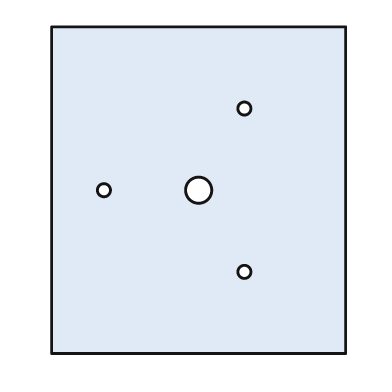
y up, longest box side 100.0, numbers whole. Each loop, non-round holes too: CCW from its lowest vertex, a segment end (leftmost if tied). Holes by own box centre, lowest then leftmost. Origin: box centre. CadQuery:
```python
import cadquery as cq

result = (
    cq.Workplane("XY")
    .moveTo(-45.0, -50.0)
    .lineTo(45.0, -50.0)
    .lineTo(45.0, 50.0)
    .lineTo(-45.0, 50.0)
    .close()
    .moveTo(14.0, -25.0)
    .circle(2.0)
    .moveTo(-29.0, 0.0)
    .circle(2.0)
    .moveTo(0.0, 0.0)
    .circle(4.0)
    .moveTo(14.0, 25.0)
    .circle(2.0)
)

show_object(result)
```